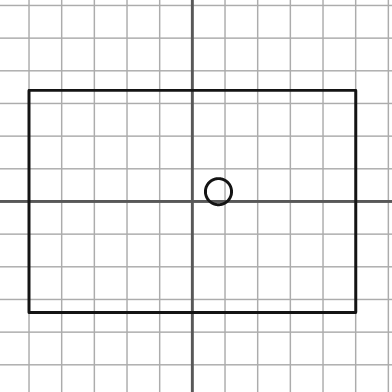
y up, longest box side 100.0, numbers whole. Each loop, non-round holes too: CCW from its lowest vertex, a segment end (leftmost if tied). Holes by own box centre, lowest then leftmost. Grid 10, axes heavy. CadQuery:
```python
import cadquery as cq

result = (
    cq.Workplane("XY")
    .moveTo(-50.0, -34.0)
    .lineTo(50.0, -34.0)
    .lineTo(50.0, 34.0)
    .lineTo(-50.0, 34.0)
    .close()
    .moveTo(8.0, 3.0)
    .circle(4.0)
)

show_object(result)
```